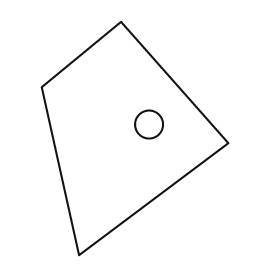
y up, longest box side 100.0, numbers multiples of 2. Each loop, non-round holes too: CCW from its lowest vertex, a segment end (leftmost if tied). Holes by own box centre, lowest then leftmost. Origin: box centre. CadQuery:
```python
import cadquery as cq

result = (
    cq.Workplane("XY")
    .moveTo(-24.0, -50.0)
    .lineTo(40.0, -2.0)
    .lineTo(-6.0, 50.0)
    .lineTo(-40.0, 22.0)
    .close()
    .moveTo(6.0, 6.0)
    .circle(6.0)
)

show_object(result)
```